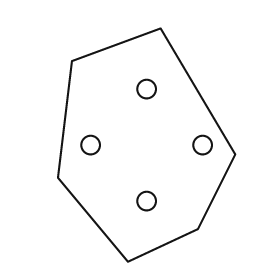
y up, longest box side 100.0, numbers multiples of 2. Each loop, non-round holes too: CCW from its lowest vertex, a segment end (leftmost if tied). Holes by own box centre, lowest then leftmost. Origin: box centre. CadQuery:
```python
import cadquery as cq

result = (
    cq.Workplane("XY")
    .moveTo(-8.0, -50.0)
    .lineTo(22.0, -36.0)
    .lineTo(38.0, -4.0)
    .lineTo(6.0, 50.0)
    .lineTo(-32.0, 36.0)
    .lineTo(-38.0, -14.0)
    .close()
    .moveTo(0.0, -24.0)
    .circle(4.0)
    .moveTo(-24.0, 0.0)
    .circle(4.0)
    .moveTo(24.0, 0.0)
    .circle(4.0)
    .moveTo(0.0, 24.0)
    .circle(4.0)
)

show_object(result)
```